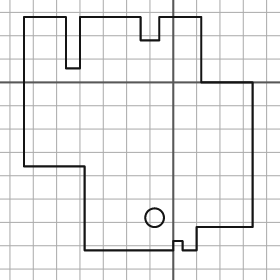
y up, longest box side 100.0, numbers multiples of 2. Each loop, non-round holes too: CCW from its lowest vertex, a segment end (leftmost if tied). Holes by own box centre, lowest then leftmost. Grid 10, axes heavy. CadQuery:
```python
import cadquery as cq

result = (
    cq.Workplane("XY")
    .moveTo(-38.0, -72.0)
    .lineTo(0.0, -72.0)
    .lineTo(0.0, -68.0)
    .lineTo(4.0, -68.0)
    .lineTo(4.0, -72.0)
    .lineTo(10.0, -72.0)
    .lineTo(10.0, -62.0)
    .lineTo(34.0, -62.0)
    .lineTo(34.0, 0.0)
    .lineTo(12.0, 0.0)
    .lineTo(12.0, 28.0)
    .lineTo(-6.0, 28.0)
    .lineTo(-6.0, 18.0)
    .lineTo(-14.0, 18.0)
    .lineTo(-14.0, 28.0)
    .lineTo(-40.0, 28.0)
    .lineTo(-40.0, 6.0)
    .lineTo(-46.0, 6.0)
    .lineTo(-46.0, 28.0)
    .lineTo(-64.0, 28.0)
    .lineTo(-64.0, -36.0)
    .lineTo(-38.0, -36.0)
    .close()
    .moveTo(-8.0, -58.0)
    .circle(4.0)
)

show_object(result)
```